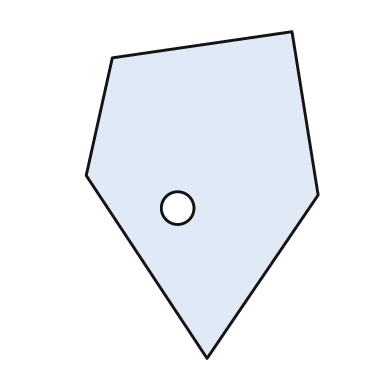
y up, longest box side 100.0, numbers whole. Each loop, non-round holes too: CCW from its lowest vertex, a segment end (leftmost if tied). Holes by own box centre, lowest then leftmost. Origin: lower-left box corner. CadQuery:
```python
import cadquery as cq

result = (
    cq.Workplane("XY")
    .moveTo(37.0, 0.0)
    .lineTo(71.0, 50.0)
    .lineTo(63.0, 100.0)
    .lineTo(8.0, 92.0)
    .lineTo(0.0, 56.0)
    .close()
    .moveTo(28.0, 46.0)
    .circle(5.0)
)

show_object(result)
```